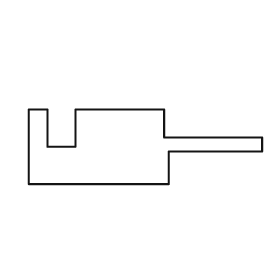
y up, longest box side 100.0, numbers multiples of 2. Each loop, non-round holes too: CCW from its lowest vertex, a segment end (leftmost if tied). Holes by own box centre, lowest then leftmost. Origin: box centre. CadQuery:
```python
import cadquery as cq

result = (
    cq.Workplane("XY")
    .moveTo(-50.0, -16.0)
    .lineTo(10.0, -16.0)
    .lineTo(10.0, -2.0)
    .lineTo(50.0, -2.0)
    .lineTo(50.0, 4.0)
    .lineTo(8.0, 4.0)
    .lineTo(8.0, 16.0)
    .lineTo(-30.0, 16.0)
    .lineTo(-30.0, 0.0)
    .lineTo(-42.0, 0.0)
    .lineTo(-42.0, 16.0)
    .lineTo(-50.0, 16.0)
    .close()
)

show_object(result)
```